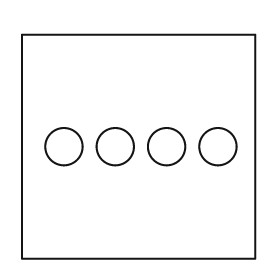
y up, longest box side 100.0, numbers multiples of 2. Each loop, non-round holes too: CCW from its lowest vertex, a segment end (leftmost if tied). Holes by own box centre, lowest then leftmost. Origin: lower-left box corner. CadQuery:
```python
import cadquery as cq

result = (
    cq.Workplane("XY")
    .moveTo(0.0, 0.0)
    .lineTo(100.0, 0.0)
    .lineTo(100.0, 96.0)
    .lineTo(0.0, 96.0)
    .close()
    .moveTo(18.0, 48.0)
    .circle(8.0)
    .moveTo(40.0, 48.0)
    .circle(8.0)
    .moveTo(62.0, 48.0)
    .circle(8.0)
    .moveTo(84.0, 48.0)
    .circle(8.0)
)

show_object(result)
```